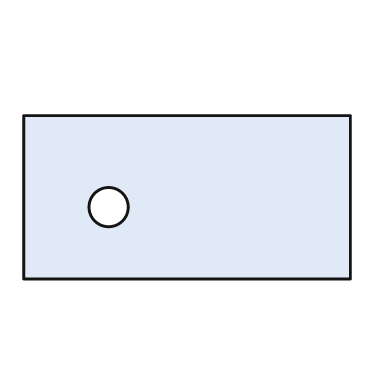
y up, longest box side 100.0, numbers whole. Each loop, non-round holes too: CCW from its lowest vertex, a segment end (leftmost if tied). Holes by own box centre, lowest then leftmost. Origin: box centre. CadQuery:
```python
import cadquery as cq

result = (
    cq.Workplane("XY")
    .moveTo(-50.0, -25.0)
    .lineTo(50.0, -25.0)
    .lineTo(50.0, 25.0)
    .lineTo(-50.0, 25.0)
    .close()
    .moveTo(-24.0, -3.0)
    .circle(6.0)
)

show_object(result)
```